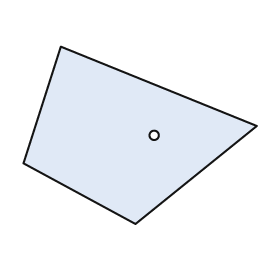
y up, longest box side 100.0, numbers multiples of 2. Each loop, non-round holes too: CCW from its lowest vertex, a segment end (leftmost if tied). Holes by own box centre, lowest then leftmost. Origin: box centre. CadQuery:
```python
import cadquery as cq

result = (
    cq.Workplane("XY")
    .moveTo(-2.0, -38.0)
    .lineTo(50.0, 4.0)
    .lineTo(-34.0, 38.0)
    .lineTo(-50.0, -12.0)
    .close()
    .moveTo(6.0, 0.0)
    .circle(2.0)
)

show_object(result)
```